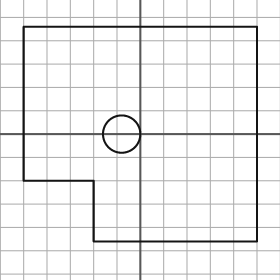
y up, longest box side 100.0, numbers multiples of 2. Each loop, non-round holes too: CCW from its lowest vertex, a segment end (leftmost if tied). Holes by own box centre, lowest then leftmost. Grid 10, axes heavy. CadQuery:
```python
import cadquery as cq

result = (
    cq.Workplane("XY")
    .moveTo(-20.0, -46.0)
    .lineTo(50.0, -46.0)
    .lineTo(50.0, 46.0)
    .lineTo(-50.0, 46.0)
    .lineTo(-50.0, -20.0)
    .lineTo(-20.0, -20.0)
    .close()
    .moveTo(-8.0, 0.0)
    .circle(8.0)
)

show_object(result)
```